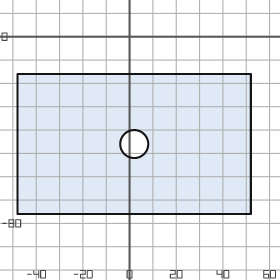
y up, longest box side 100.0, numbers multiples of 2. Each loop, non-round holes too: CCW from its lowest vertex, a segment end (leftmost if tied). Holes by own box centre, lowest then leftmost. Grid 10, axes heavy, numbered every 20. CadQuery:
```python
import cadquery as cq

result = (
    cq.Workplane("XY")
    .moveTo(-48.0, -76.0)
    .lineTo(52.0, -76.0)
    .lineTo(52.0, -16.0)
    .lineTo(-48.0, -16.0)
    .close()
    .moveTo(2.0, -46.0)
    .circle(6.0)
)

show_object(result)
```